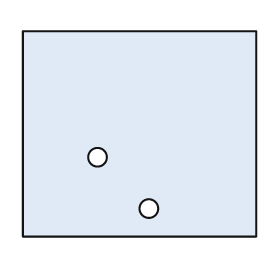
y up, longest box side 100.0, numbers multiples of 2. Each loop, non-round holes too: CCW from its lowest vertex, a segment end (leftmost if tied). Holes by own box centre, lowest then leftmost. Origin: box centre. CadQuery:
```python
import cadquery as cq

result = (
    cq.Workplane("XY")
    .moveTo(-50.0, -44.0)
    .lineTo(50.0, -44.0)
    .lineTo(50.0, 44.0)
    .lineTo(-50.0, 44.0)
    .close()
    .moveTo(4.0, -32.0)
    .circle(4.0)
    .moveTo(-18.0, -10.0)
    .circle(4.0)
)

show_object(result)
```